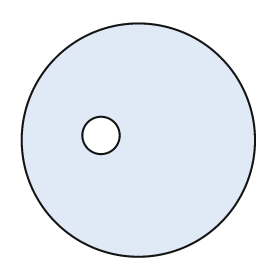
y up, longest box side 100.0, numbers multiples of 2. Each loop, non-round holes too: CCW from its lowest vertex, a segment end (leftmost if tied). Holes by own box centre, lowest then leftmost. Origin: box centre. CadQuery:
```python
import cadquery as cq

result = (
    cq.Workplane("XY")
    .moveTo(0.0, 0.0)
    .circle(50.0)
    .moveTo(-16.0, 2.0)
    .circle(8.0)
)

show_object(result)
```